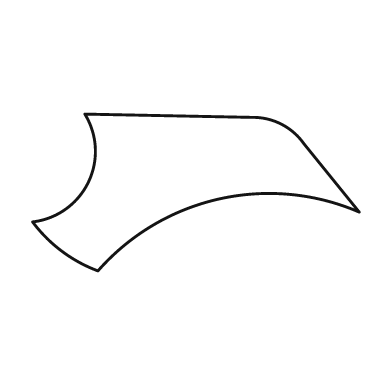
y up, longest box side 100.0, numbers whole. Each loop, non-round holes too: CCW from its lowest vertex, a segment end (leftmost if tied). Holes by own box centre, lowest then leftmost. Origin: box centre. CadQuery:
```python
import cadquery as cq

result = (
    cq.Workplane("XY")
    .moveTo(-30.0, -24.0)
    .threePointArc((7.0, -2.0), (50.0, -6.0))
    .lineTo(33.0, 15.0)
    .threePointArc((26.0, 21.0), (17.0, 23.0))
    .lineTo(-34.0, 24.0)
    .threePointArc((-33.0, 3.0), (-50.0, -9.0))
    .threePointArc((-41.0, -18.0), (-30.0, -24.0))
    .close()
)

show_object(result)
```